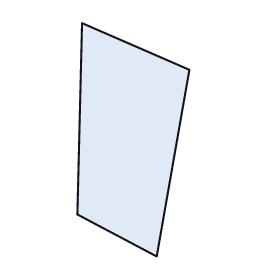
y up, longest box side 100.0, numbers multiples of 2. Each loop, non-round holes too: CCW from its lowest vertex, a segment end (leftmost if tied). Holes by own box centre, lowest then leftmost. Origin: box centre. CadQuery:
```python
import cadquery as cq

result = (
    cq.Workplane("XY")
    .moveTo(10.0, -50.0)
    .lineTo(24.0, 30.0)
    .lineTo(-22.0, 50.0)
    .lineTo(-24.0, -32.0)
    .close()
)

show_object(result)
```